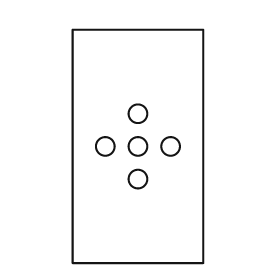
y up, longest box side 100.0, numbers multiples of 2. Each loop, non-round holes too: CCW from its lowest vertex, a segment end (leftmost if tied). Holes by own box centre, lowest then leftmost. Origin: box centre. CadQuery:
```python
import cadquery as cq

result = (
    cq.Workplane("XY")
    .moveTo(-28.0, -50.0)
    .lineTo(28.0, -50.0)
    .lineTo(28.0, 50.0)
    .lineTo(-28.0, 50.0)
    .close()
    .moveTo(0.0, -14.0)
    .circle(4.0)
    .moveTo(-14.0, 0.0)
    .circle(4.0)
    .moveTo(0.0, 0.0)
    .circle(4.0)
    .moveTo(14.0, 0.0)
    .circle(4.0)
    .moveTo(0.0, 14.0)
    .circle(4.0)
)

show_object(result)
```